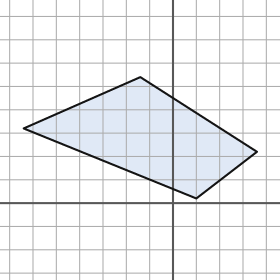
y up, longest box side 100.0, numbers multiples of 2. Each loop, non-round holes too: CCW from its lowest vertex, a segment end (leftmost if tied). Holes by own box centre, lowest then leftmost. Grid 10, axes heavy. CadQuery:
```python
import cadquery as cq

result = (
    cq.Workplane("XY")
    .moveTo(10.0, 2.0)
    .lineTo(36.0, 22.0)
    .lineTo(-14.0, 54.0)
    .lineTo(-64.0, 32.0)
    .close()
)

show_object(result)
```